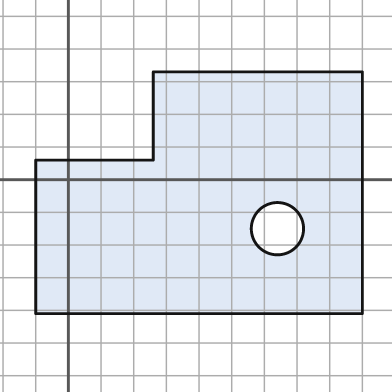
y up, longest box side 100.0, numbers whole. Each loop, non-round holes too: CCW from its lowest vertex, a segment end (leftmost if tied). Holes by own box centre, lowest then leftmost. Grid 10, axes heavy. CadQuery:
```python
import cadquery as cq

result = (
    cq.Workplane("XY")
    .moveTo(-10.0, -41.0)
    .lineTo(90.0, -41.0)
    .lineTo(90.0, 33.0)
    .lineTo(26.0, 33.0)
    .lineTo(26.0, 6.0)
    .lineTo(-10.0, 6.0)
    .close()
    .moveTo(64.0, -15.0)
    .circle(8.0)
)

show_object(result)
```